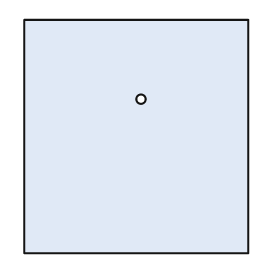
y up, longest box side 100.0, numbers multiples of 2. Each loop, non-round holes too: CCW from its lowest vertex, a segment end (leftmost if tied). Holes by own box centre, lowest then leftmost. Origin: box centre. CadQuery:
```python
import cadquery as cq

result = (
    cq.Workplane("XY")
    .moveTo(-48.0, -50.0)
    .lineTo(48.0, -50.0)
    .lineTo(48.0, 50.0)
    .lineTo(-48.0, 50.0)
    .close()
    .moveTo(2.0, 16.0)
    .circle(2.0)
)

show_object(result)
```